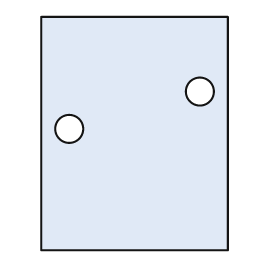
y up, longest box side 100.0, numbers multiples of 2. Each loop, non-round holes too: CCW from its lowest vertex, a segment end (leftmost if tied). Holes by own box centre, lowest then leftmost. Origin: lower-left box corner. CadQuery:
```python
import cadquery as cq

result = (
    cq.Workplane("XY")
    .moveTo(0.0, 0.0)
    .lineTo(80.0, 0.0)
    .lineTo(80.0, 100.0)
    .lineTo(0.0, 100.0)
    .close()
    .moveTo(12.0, 52.0)
    .circle(6.0)
    .moveTo(68.0, 68.0)
    .circle(6.0)
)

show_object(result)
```